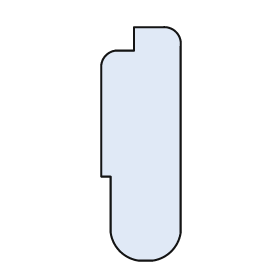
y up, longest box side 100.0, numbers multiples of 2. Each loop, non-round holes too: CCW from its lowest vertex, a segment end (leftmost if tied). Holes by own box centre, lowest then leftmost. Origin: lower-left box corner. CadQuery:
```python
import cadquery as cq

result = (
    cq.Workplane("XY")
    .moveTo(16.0, 0.0)
    .lineTo(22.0, 0.0)
    .threePointArc((30.0, 4.0), (34.0, 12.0))
    .lineTo(34.0, 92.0)
    .threePointArc((32.0, 98.0), (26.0, 100.0))
    .lineTo(14.0, 100.0)
    .lineTo(14.0, 90.0)
    .lineTo(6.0, 90.0)
    .threePointArc((2.0, 88.0), (0.0, 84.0))
    .lineTo(0.0, 36.0)
    .lineTo(4.0, 36.0)
    .lineTo(4.0, 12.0)
    .threePointArc((8.0, 4.0), (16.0, 0.0))
    .close()
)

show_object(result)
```